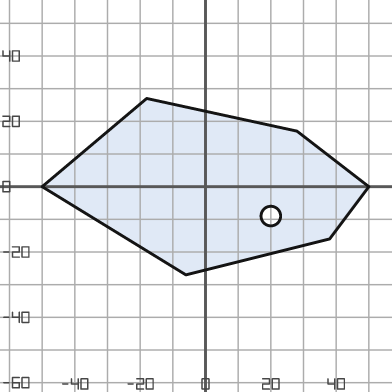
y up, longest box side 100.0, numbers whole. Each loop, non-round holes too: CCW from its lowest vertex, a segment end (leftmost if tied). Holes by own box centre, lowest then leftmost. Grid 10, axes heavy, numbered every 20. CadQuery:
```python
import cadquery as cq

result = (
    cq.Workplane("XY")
    .moveTo(-6.0, -27.0)
    .lineTo(38.0, -16.0)
    .lineTo(50.0, 0.0)
    .lineTo(28.0, 17.0)
    .lineTo(-18.0, 27.0)
    .lineTo(-50.0, 0.0)
    .close()
    .moveTo(20.0, -9.0)
    .circle(3.0)
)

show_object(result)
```